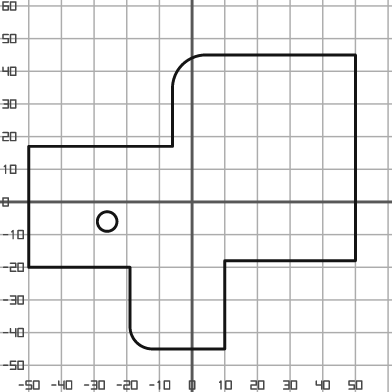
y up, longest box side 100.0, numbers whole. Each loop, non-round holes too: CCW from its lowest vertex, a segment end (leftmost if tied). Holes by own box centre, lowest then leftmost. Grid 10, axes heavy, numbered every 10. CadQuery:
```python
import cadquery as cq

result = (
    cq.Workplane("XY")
    .moveTo(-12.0, -45.0)
    .lineTo(10.0, -45.0)
    .lineTo(10.0, -18.0)
    .lineTo(50.0, -18.0)
    .lineTo(50.0, 45.0)
    .lineTo(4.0, 45.0)
    .threePointArc((-3.0, 42.0), (-6.0, 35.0))
    .lineTo(-6.0, 17.0)
    .lineTo(-50.0, 17.0)
    .lineTo(-50.0, -20.0)
    .lineTo(-19.0, -20.0)
    .lineTo(-19.0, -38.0)
    .threePointArc((-17.0, -43.0), (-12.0, -45.0))
    .close()
    .moveTo(-26.0, -6.0)
    .circle(3.0)
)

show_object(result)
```